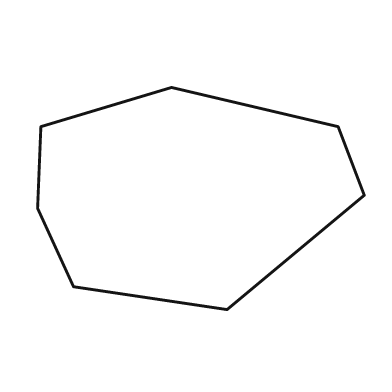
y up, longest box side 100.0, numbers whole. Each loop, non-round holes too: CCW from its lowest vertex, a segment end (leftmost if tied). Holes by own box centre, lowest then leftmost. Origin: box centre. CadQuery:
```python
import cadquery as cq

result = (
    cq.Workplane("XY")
    .moveTo(8.0, -34.0)
    .lineTo(50.0, 1.0)
    .lineTo(42.0, 22.0)
    .lineTo(-9.0, 34.0)
    .lineTo(-49.0, 22.0)
    .lineTo(-50.0, -3.0)
    .lineTo(-39.0, -27.0)
    .close()
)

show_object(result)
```